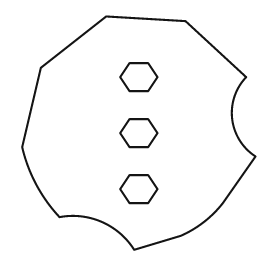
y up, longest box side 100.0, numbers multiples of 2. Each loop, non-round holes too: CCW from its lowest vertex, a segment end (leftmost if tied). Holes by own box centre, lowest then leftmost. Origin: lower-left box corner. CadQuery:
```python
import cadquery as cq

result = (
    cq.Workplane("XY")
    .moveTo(48.0, 0.0)
    .lineTo(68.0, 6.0)
    .threePointArc((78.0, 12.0), (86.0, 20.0))
    .lineTo(100.0, 40.0)
    .threePointArc((90.0, 56.0), (96.0, 74.0))
    .lineTo(70.0, 98.0)
    .lineTo(36.0, 100.0)
    .lineTo(8.0, 78.0)
    .lineTo(0.0, 44.0)
    .threePointArc((6.0, 28.0), (16.0, 14.0))
    .threePointArc((34.0, 12.0), (48.0, 0.0))
    .close()
    .moveTo(46.0, 20.0)
    .lineTo(54.0, 20.0)
    .lineTo(58.0, 26.0)
    .lineTo(54.0, 32.0)
    .lineTo(46.0, 32.0)
    .lineTo(42.0, 26.0)
    .close()
    .moveTo(46.0, 44.0)
    .lineTo(54.0, 44.0)
    .lineTo(58.0, 50.0)
    .lineTo(54.0, 56.0)
    .lineTo(46.0, 56.0)
    .lineTo(42.0, 50.0)
    .close()
    .moveTo(46.0, 68.0)
    .lineTo(54.0, 68.0)
    .lineTo(58.0, 74.0)
    .lineTo(54.0, 80.0)
    .lineTo(46.0, 80.0)
    .lineTo(42.0, 74.0)
    .close()
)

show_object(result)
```